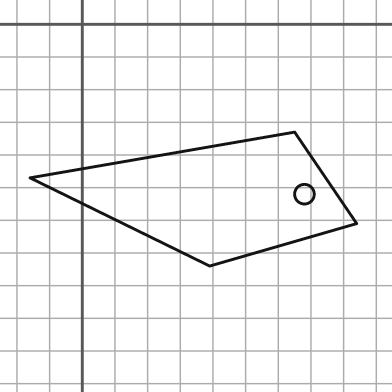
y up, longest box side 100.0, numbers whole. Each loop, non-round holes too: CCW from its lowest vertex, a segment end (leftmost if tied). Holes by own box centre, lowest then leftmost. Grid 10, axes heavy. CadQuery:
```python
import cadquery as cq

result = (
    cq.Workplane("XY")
    .moveTo(39.0, -74.0)
    .lineTo(84.0, -61.0)
    .lineTo(65.0, -33.0)
    .lineTo(-16.0, -47.0)
    .close()
    .moveTo(68.0, -52.0)
    .circle(3.0)
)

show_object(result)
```